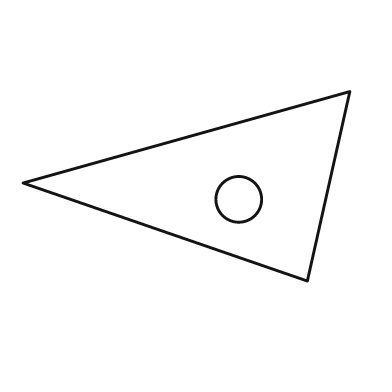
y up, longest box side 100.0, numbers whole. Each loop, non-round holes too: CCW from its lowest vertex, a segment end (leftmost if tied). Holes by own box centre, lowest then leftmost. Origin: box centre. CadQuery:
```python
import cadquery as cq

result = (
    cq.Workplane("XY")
    .moveTo(37.0, -29.0)
    .lineTo(50.0, 29.0)
    .lineTo(-50.0, 1.0)
    .close()
    .moveTo(16.0, -4.0)
    .circle(7.0)
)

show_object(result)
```